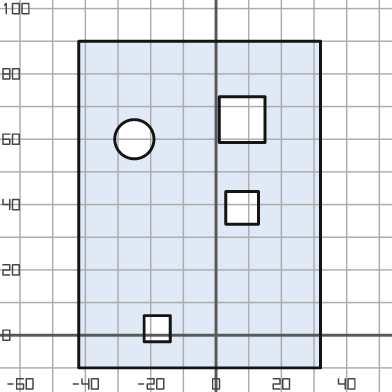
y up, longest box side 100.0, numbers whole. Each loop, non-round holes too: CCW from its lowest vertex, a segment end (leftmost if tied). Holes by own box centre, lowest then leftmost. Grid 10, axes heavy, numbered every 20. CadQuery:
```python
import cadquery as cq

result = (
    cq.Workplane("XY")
    .moveTo(-42.0, -10.0)
    .lineTo(32.0, -10.0)
    .lineTo(32.0, 90.0)
    .lineTo(-42.0, 90.0)
    .close()
    .moveTo(-22.0, -2.0)
    .lineTo(-14.0, -2.0)
    .lineTo(-14.0, 6.0)
    .lineTo(-22.0, 6.0)
    .close()
    .moveTo(3.0, 34.0)
    .lineTo(13.0, 34.0)
    .lineTo(13.0, 44.0)
    .lineTo(3.0, 44.0)
    .close()
    .moveTo(-25.0, 60.0)
    .circle(6.0)
    .moveTo(1.0, 59.0)
    .lineTo(15.0, 59.0)
    .lineTo(15.0, 73.0)
    .lineTo(1.0, 73.0)
    .close()
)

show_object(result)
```